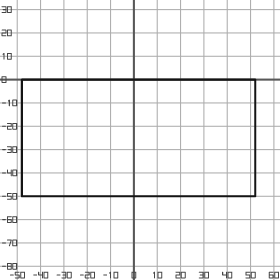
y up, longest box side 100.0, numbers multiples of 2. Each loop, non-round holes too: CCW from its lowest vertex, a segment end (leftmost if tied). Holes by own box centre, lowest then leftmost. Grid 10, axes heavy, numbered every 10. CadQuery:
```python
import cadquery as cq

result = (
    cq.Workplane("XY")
    .moveTo(-48.0, -50.0)
    .lineTo(52.0, -50.0)
    .lineTo(52.0, 0.0)
    .lineTo(-48.0, 0.0)
    .close()
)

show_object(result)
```